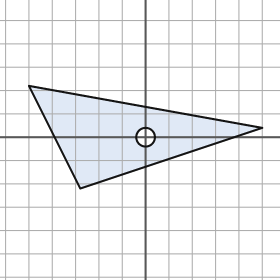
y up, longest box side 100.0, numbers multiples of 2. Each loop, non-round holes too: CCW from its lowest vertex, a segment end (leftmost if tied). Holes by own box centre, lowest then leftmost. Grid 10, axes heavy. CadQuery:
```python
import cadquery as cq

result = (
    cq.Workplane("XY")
    .moveTo(-28.0, -22.0)
    .lineTo(50.0, 4.0)
    .lineTo(-50.0, 22.0)
    .close()
    .moveTo(0.0, 0.0)
    .circle(4.0)
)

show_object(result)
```